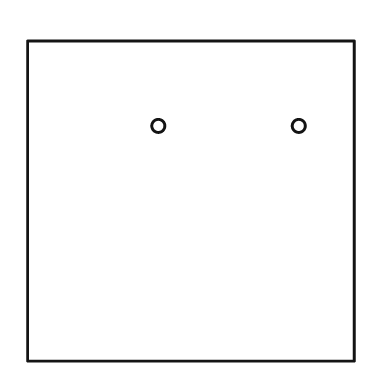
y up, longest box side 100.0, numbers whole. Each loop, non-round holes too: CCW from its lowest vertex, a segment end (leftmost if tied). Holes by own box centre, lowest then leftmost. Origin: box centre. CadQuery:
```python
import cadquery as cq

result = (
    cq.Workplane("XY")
    .moveTo(-50.0, -49.0)
    .lineTo(50.0, -49.0)
    .lineTo(50.0, 49.0)
    .lineTo(-50.0, 49.0)
    .close()
    .moveTo(-10.0, 23.0)
    .circle(2.0)
    .moveTo(33.0, 23.0)
    .circle(2.0)
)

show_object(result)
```